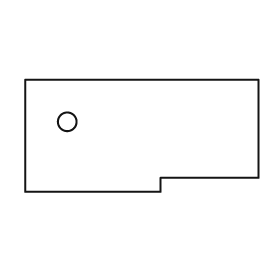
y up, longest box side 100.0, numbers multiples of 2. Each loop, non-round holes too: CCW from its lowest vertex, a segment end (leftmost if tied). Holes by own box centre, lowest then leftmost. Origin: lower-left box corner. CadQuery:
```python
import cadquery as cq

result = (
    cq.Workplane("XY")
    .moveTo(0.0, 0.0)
    .lineTo(58.0, 0.0)
    .lineTo(58.0, 6.0)
    .lineTo(100.0, 6.0)
    .lineTo(100.0, 48.0)
    .lineTo(0.0, 48.0)
    .close()
    .moveTo(18.0, 30.0)
    .circle(4.0)
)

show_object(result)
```